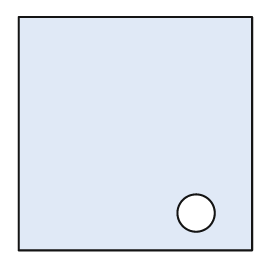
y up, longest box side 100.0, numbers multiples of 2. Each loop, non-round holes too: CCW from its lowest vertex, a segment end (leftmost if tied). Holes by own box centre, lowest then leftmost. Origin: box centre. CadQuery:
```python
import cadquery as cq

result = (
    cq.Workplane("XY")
    .moveTo(-50.0, -50.0)
    .lineTo(50.0, -50.0)
    .lineTo(50.0, 50.0)
    .lineTo(-50.0, 50.0)
    .close()
    .moveTo(26.0, -34.0)
    .circle(8.0)
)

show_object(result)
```